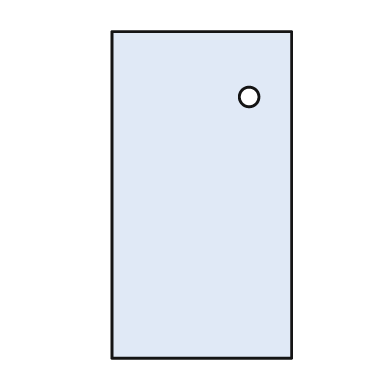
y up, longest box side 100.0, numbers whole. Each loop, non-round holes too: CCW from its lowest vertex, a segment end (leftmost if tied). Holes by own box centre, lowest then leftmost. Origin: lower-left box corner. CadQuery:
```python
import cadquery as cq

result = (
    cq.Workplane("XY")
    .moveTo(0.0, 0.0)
    .lineTo(55.0, 0.0)
    .lineTo(55.0, 100.0)
    .lineTo(0.0, 100.0)
    .close()
    .moveTo(42.0, 80.0)
    .circle(3.0)
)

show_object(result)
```